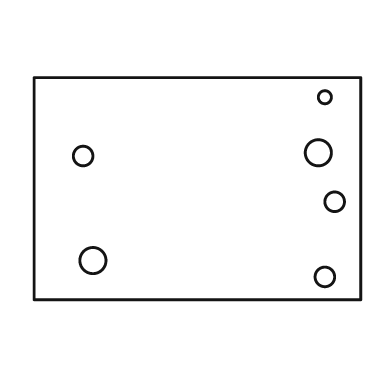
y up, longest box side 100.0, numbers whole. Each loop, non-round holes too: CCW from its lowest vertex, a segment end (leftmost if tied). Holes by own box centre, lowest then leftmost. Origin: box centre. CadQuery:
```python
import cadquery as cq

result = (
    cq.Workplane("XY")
    .moveTo(-50.0, -34.0)
    .lineTo(50.0, -34.0)
    .lineTo(50.0, 34.0)
    .lineTo(-50.0, 34.0)
    .close()
    .moveTo(39.0, -27.0)
    .circle(3.0)
    .moveTo(-32.0, -22.0)
    .circle(4.0)
    .moveTo(42.0, -4.0)
    .circle(3.0)
    .moveTo(-35.0, 10.0)
    .circle(3.0)
    .moveTo(37.0, 11.0)
    .circle(4.0)
    .moveTo(39.0, 28.0)
    .circle(2.0)
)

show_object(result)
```